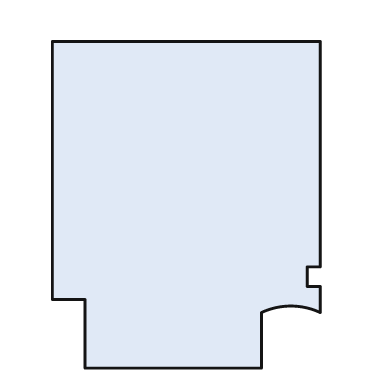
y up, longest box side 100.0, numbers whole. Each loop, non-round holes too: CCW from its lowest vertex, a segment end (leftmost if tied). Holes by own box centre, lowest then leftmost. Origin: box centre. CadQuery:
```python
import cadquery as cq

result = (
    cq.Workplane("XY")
    .moveTo(-31.0, -50.0)
    .lineTo(23.0, -50.0)
    .lineTo(23.0, -33.0)
    .threePointArc((32.0, -31.0), (41.0, -33.0))
    .lineTo(41.0, -25.0)
    .lineTo(37.0, -25.0)
    .lineTo(37.0, -19.0)
    .lineTo(41.0, -19.0)
    .lineTo(41.0, 50.0)
    .lineTo(-41.0, 50.0)
    .lineTo(-41.0, -29.0)
    .lineTo(-31.0, -29.0)
    .close()
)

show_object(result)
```